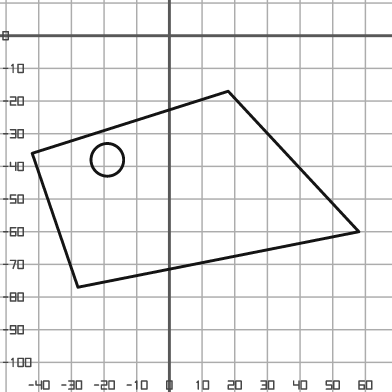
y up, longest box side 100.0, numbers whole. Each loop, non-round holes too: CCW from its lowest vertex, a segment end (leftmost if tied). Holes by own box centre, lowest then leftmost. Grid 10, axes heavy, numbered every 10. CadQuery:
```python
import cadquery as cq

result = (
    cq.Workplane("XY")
    .moveTo(-28.0, -77.0)
    .lineTo(58.0, -60.0)
    .lineTo(18.0, -17.0)
    .lineTo(-42.0, -36.0)
    .close()
    .moveTo(-19.0, -38.0)
    .circle(5.0)
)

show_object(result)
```